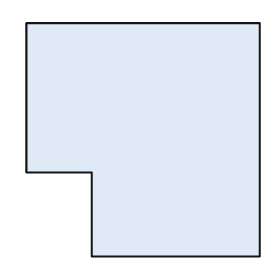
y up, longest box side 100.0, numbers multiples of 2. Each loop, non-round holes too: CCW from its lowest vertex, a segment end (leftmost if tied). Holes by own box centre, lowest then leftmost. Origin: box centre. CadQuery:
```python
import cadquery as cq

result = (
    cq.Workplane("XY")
    .moveTo(-22.0, -50.0)
    .lineTo(50.0, -50.0)
    .lineTo(50.0, 50.0)
    .lineTo(-50.0, 50.0)
    .lineTo(-50.0, -14.0)
    .lineTo(-22.0, -14.0)
    .close()
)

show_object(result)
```